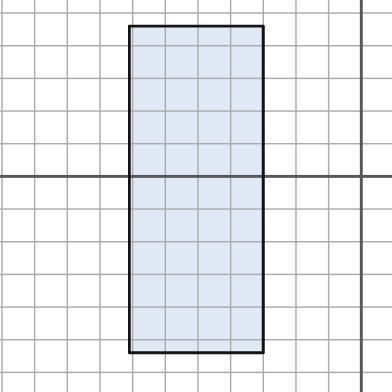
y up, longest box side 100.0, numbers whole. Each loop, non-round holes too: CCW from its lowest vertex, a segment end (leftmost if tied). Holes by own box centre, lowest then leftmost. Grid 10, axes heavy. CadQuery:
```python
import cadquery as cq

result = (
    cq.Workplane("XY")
    .moveTo(-71.0, -54.0)
    .lineTo(-30.0, -54.0)
    .lineTo(-30.0, 46.0)
    .lineTo(-71.0, 46.0)
    .close()
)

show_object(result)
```